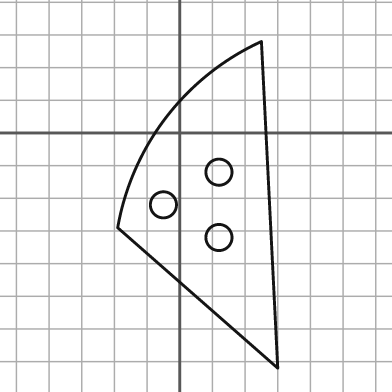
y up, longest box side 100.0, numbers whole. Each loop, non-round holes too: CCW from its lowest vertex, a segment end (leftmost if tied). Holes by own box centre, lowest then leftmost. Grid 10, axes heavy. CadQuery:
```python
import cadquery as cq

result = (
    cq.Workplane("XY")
    .moveTo(30.0, -72.0)
    .lineTo(25.0, 28.0)
    .threePointArc((-4.0, 5.0), (-19.0, -29.0))
    .close()
    .moveTo(12.0, -32.0)
    .circle(4.0)
    .moveTo(-5.0, -22.0)
    .circle(4.0)
    .moveTo(12.0, -12.0)
    .circle(4.0)
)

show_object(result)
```